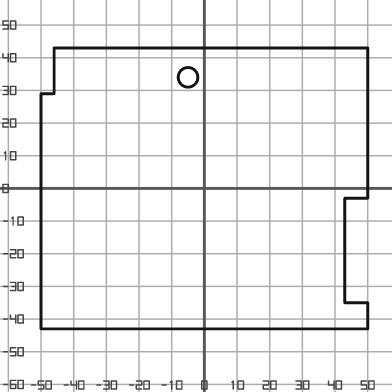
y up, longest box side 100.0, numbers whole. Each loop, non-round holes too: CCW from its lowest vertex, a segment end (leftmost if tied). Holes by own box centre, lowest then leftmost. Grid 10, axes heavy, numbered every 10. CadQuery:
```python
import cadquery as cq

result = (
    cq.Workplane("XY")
    .moveTo(-50.0, -43.0)
    .lineTo(50.0, -43.0)
    .lineTo(50.0, -35.0)
    .lineTo(43.0, -35.0)
    .lineTo(43.0, -3.0)
    .lineTo(50.0, -3.0)
    .lineTo(50.0, 43.0)
    .lineTo(-46.0, 43.0)
    .lineTo(-46.0, 29.0)
    .lineTo(-50.0, 29.0)
    .close()
    .moveTo(-5.0, 34.0)
    .circle(3.0)
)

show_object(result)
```